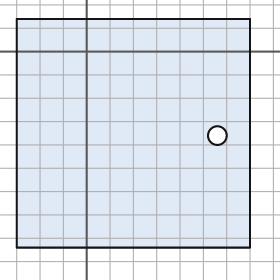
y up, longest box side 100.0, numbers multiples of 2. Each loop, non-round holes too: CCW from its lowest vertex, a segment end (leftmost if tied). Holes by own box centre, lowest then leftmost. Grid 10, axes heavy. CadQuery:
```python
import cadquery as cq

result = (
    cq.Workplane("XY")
    .moveTo(-30.0, -84.0)
    .lineTo(70.0, -84.0)
    .lineTo(70.0, 14.0)
    .lineTo(-30.0, 14.0)
    .close()
    .moveTo(56.0, -36.0)
    .circle(4.0)
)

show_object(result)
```